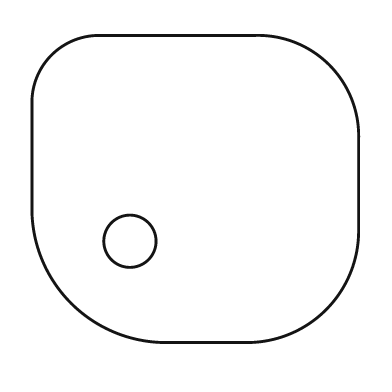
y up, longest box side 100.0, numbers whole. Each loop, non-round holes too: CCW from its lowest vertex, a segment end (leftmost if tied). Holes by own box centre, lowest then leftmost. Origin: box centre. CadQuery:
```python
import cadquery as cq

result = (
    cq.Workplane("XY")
    .moveTo(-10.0, -47.0)
    .lineTo(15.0, -47.0)
    .threePointArc((40.0, -37.0), (50.0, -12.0))
    .lineTo(50.0, 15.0)
    .threePointArc((41.0, 38.0), (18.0, 47.0))
    .lineTo(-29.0, 47.0)
    .threePointArc((-44.0, 41.0), (-50.0, 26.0))
    .lineTo(-50.0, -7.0)
    .threePointArc((-38.0, -35.0), (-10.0, -47.0))
    .close()
    .moveTo(-20.0, -16.0)
    .circle(8.0)
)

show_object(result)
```